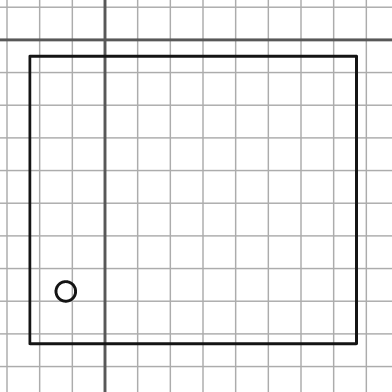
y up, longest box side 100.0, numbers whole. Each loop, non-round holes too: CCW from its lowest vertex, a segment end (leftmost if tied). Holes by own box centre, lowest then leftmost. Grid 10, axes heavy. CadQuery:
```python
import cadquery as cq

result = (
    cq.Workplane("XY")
    .moveTo(-23.0, -93.0)
    .lineTo(77.0, -93.0)
    .lineTo(77.0, -5.0)
    .lineTo(-23.0, -5.0)
    .close()
    .moveTo(-12.0, -77.0)
    .circle(3.0)
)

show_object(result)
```